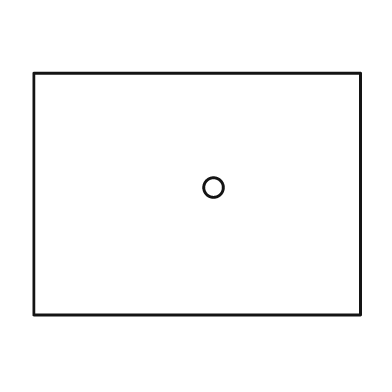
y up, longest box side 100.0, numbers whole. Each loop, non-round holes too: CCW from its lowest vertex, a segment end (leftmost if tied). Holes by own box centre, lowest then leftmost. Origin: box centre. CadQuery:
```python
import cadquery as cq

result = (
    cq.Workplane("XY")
    .moveTo(-50.0, -37.0)
    .lineTo(50.0, -37.0)
    .lineTo(50.0, 37.0)
    .lineTo(-50.0, 37.0)
    .close()
    .moveTo(5.0, 2.0)
    .circle(3.0)
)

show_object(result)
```